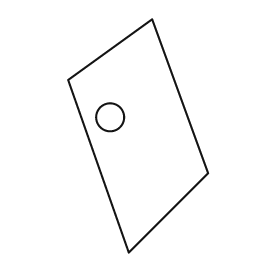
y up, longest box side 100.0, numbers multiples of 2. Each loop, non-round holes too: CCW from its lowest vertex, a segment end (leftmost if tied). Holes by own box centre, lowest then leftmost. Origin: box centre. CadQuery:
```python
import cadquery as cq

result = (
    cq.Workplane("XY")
    .moveTo(-4.0, -50.0)
    .lineTo(30.0, -16.0)
    .lineTo(6.0, 50.0)
    .lineTo(-30.0, 24.0)
    .close()
    .moveTo(-12.0, 8.0)
    .circle(6.0)
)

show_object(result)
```